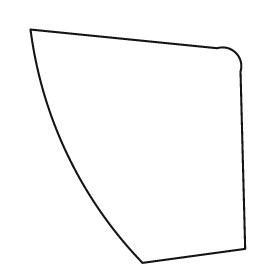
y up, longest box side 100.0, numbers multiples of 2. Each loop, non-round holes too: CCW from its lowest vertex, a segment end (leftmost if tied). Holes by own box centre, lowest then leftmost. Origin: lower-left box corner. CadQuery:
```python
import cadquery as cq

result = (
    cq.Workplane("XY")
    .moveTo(48.0, 0.0)
    .lineTo(92.0, 6.0)
    .lineTo(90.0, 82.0)
    .threePointArc((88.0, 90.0), (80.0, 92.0))
    .lineTo(0.0, 100.0)
    .threePointArc((16.0, 46.0), (48.0, 0.0))
    .close()
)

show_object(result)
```